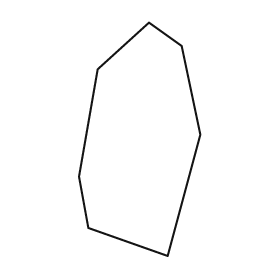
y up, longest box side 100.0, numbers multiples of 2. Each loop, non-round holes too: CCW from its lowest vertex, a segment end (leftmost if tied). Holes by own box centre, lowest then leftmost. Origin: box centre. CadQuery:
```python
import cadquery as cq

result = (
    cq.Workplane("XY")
    .moveTo(12.0, -50.0)
    .lineTo(26.0, 2.0)
    .lineTo(18.0, 40.0)
    .lineTo(4.0, 50.0)
    .lineTo(-18.0, 30.0)
    .lineTo(-26.0, -16.0)
    .lineTo(-22.0, -38.0)
    .close()
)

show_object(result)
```